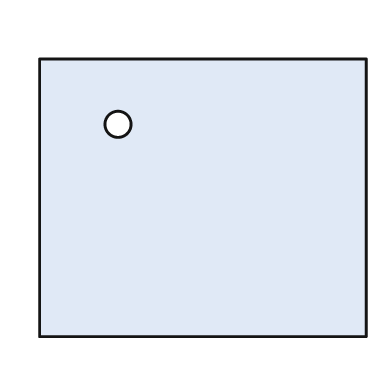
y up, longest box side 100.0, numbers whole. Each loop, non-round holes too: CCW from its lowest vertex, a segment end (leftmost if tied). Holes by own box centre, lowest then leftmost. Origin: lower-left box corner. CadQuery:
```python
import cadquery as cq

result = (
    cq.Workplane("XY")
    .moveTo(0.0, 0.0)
    .lineTo(100.0, 0.0)
    .lineTo(100.0, 85.0)
    .lineTo(0.0, 85.0)
    .close()
    .moveTo(24.0, 65.0)
    .circle(4.0)
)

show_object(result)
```